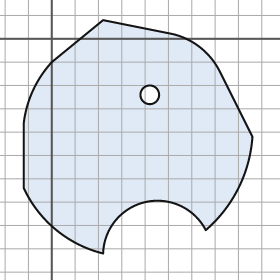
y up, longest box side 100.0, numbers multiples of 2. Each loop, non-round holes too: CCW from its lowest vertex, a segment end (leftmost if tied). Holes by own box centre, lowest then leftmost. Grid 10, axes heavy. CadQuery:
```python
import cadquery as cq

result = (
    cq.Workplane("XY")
    .moveTo(22.0, -92.0)
    .threePointArc((40.0, -70.0), (66.0, -82.0))
    .threePointArc((80.0, -64.0), (86.0, -42.0))
    .lineTo(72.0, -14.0)
    .threePointArc((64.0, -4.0), (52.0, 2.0))
    .lineTo(22.0, 8.0)
    .lineTo(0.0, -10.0)
    .threePointArc((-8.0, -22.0), (-12.0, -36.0))
    .lineTo(-12.0, -64.0)
    .threePointArc((2.0, -82.0), (22.0, -92.0))
    .close()
    .moveTo(42.0, -24.0)
    .circle(4.0)
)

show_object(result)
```